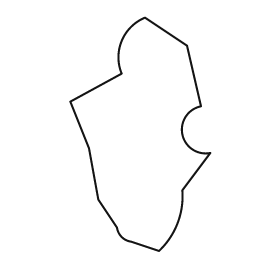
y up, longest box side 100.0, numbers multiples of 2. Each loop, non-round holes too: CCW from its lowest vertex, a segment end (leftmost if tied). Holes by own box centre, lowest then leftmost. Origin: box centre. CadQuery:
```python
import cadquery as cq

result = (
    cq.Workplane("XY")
    .moveTo(8.0, -50.0)
    .threePointArc((16.0, -38.0), (18.0, -24.0))
    .lineTo(30.0, -8.0)
    .threePointArc((18.0, 0.0), (26.0, 12.0))
    .lineTo(20.0, 38.0)
    .lineTo(2.0, 50.0)
    .threePointArc((-8.0, 40.0), (-8.0, 26.0))
    .lineTo(-30.0, 14.0)
    .lineTo(-22.0, -6.0)
    .lineTo(-18.0, -28.0)
    .lineTo(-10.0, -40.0)
    .threePointArc((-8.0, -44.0), (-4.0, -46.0))
    .close()
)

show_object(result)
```